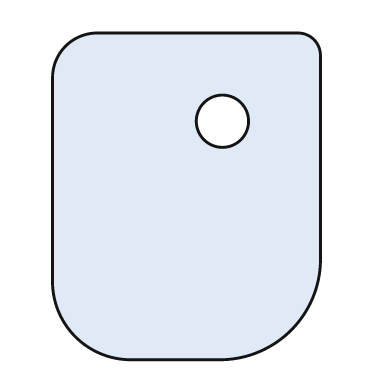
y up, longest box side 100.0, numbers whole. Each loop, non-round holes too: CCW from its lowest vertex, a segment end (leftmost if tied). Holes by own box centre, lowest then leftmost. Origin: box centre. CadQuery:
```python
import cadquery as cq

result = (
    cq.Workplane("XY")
    .moveTo(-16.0, -50.0)
    .lineTo(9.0, -50.0)
    .threePointArc((32.0, -41.0), (41.0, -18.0))
    .lineTo(41.0, 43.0)
    .threePointArc((39.0, 48.0), (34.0, 50.0))
    .lineTo(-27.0, 50.0)
    .threePointArc((-37.0, 46.0), (-41.0, 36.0))
    .lineTo(-41.0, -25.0)
    .threePointArc((-34.0, -43.0), (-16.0, -50.0))
    .close()
    .moveTo(11.0, 23.0)
    .circle(8.0)
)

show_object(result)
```